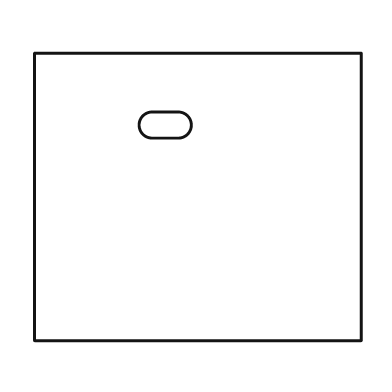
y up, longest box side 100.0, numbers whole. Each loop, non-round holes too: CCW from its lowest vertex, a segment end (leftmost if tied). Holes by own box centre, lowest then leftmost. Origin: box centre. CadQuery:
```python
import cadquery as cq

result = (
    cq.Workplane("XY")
    .moveTo(-50.0, -44.0)
    .lineTo(50.0, -44.0)
    .lineTo(50.0, 44.0)
    .lineTo(-50.0, 44.0)
    .close()
    .moveTo(-14.0, 18.0)
    .lineTo(-6.0, 18.0)
    .threePointArc((-2.0, 22.0), (-6.0, 26.0))
    .lineTo(-14.0, 26.0)
    .threePointArc((-18.0, 22.0), (-14.0, 18.0))
    .close()
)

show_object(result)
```